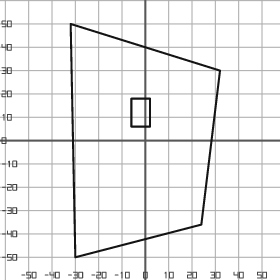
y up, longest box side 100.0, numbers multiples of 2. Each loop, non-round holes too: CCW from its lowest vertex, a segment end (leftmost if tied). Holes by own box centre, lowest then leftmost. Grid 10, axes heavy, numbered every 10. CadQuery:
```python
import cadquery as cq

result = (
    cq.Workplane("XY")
    .moveTo(-30.0, -50.0)
    .lineTo(24.0, -36.0)
    .lineTo(32.0, 30.0)
    .lineTo(-32.0, 50.0)
    .close()
    .moveTo(-6.0, 6.0)
    .lineTo(2.0, 6.0)
    .lineTo(2.0, 18.0)
    .lineTo(-6.0, 18.0)
    .close()
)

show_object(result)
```